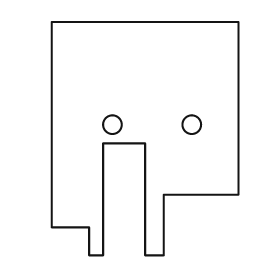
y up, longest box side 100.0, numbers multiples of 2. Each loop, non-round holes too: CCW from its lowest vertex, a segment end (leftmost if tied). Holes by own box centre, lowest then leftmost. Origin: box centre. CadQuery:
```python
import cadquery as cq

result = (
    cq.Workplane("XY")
    .moveTo(-24.0, -50.0)
    .lineTo(-18.0, -50.0)
    .lineTo(-18.0, -2.0)
    .lineTo(0.0, -2.0)
    .lineTo(0.0, -50.0)
    .lineTo(8.0, -50.0)
    .lineTo(8.0, -24.0)
    .lineTo(40.0, -24.0)
    .lineTo(40.0, 50.0)
    .lineTo(-40.0, 50.0)
    .lineTo(-40.0, -38.0)
    .lineTo(-24.0, -38.0)
    .close()
    .moveTo(-14.0, 6.0)
    .circle(4.0)
    .moveTo(20.0, 6.0)
    .circle(4.0)
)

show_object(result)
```